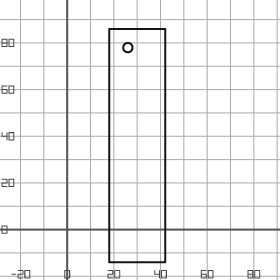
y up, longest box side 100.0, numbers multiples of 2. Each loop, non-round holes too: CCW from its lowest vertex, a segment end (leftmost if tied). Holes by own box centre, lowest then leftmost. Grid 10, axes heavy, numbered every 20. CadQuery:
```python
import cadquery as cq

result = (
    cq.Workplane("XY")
    .moveTo(18.0, -14.0)
    .lineTo(42.0, -14.0)
    .lineTo(42.0, 86.0)
    .lineTo(18.0, 86.0)
    .close()
    .moveTo(26.0, 78.0)
    .circle(2.0)
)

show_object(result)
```